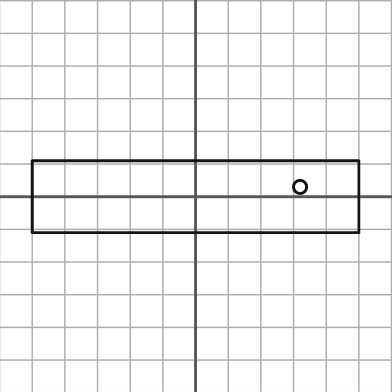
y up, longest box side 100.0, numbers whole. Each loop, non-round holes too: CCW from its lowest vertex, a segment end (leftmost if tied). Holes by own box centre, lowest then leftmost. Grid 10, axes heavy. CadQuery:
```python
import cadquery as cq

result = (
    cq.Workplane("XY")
    .moveTo(-50.0, -11.0)
    .lineTo(50.0, -11.0)
    .lineTo(50.0, 11.0)
    .lineTo(-50.0, 11.0)
    .close()
    .moveTo(32.0, 3.0)
    .circle(2.0)
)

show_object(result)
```